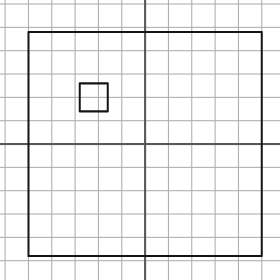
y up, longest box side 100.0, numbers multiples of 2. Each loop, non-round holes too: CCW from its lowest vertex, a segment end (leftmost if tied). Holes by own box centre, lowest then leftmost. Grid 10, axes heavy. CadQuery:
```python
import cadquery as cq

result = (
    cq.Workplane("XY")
    .moveTo(-50.0, -48.0)
    .lineTo(50.0, -48.0)
    .lineTo(50.0, 48.0)
    .lineTo(-50.0, 48.0)
    .close()
    .moveTo(-28.0, 14.0)
    .lineTo(-16.0, 14.0)
    .lineTo(-16.0, 26.0)
    .lineTo(-28.0, 26.0)
    .close()
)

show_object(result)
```